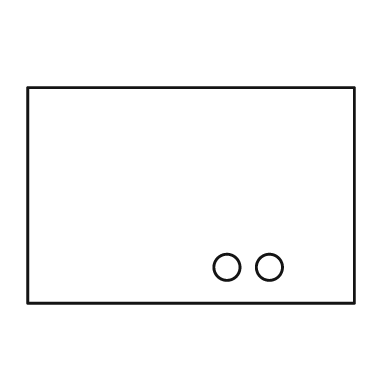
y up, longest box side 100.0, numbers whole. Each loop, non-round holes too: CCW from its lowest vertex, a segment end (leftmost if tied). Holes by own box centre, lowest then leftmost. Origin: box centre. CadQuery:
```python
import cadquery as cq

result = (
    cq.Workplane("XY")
    .moveTo(-50.0, -33.0)
    .lineTo(50.0, -33.0)
    .lineTo(50.0, 33.0)
    .lineTo(-50.0, 33.0)
    .close()
    .moveTo(11.0, -22.0)
    .circle(4.0)
    .moveTo(24.0, -22.0)
    .circle(4.0)
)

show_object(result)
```